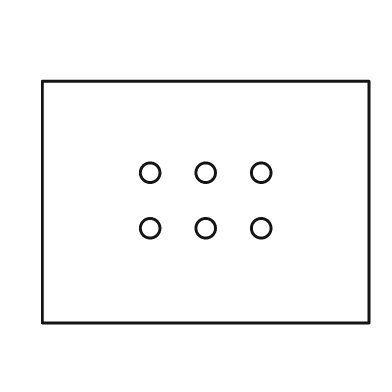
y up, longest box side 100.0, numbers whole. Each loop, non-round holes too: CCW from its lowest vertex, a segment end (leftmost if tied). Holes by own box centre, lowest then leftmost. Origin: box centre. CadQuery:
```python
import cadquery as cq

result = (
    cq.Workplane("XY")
    .moveTo(-50.0, -37.0)
    .lineTo(50.0, -37.0)
    .lineTo(50.0, 37.0)
    .lineTo(-50.0, 37.0)
    .close()
    .moveTo(-17.0, -8.0)
    .circle(3.0)
    .moveTo(0.0, -8.0)
    .circle(3.0)
    .moveTo(17.0, -8.0)
    .circle(3.0)
    .moveTo(-17.0, 9.0)
    .circle(3.0)
    .moveTo(0.0, 9.0)
    .circle(3.0)
    .moveTo(17.0, 9.0)
    .circle(3.0)
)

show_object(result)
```